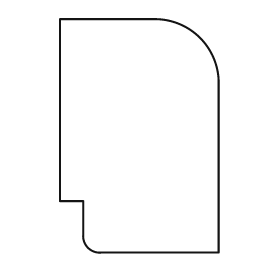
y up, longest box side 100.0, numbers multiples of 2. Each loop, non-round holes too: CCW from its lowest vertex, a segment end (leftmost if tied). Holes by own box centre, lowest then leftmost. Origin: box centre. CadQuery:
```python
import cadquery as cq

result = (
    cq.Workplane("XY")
    .moveTo(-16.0, -50.0)
    .lineTo(34.0, -50.0)
    .lineTo(34.0, 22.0)
    .threePointArc((26.0, 42.0), (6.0, 50.0))
    .lineTo(-34.0, 50.0)
    .lineTo(-34.0, -28.0)
    .lineTo(-24.0, -28.0)
    .lineTo(-24.0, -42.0)
    .threePointArc((-22.0, -48.0), (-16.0, -50.0))
    .close()
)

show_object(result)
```